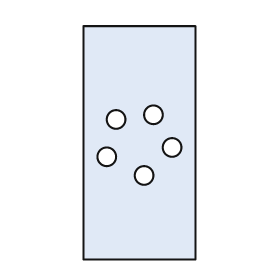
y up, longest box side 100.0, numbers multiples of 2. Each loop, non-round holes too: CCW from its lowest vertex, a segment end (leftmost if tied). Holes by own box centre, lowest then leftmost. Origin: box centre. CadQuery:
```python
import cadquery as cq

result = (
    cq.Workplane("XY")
    .moveTo(-24.0, -50.0)
    .lineTo(24.0, -50.0)
    .lineTo(24.0, 50.0)
    .lineTo(-24.0, 50.0)
    .close()
    .moveTo(2.0, -14.0)
    .circle(4.0)
    .moveTo(-14.0, -6.0)
    .circle(4.0)
    .moveTo(14.0, -2.0)
    .circle(4.0)
    .moveTo(-10.0, 10.0)
    .circle(4.0)
    .moveTo(6.0, 12.0)
    .circle(4.0)
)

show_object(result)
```